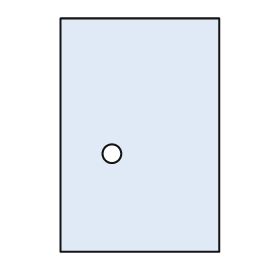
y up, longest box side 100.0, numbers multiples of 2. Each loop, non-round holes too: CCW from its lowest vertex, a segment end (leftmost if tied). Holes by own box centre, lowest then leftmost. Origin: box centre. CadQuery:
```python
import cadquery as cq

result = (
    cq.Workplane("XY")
    .moveTo(-34.0, -50.0)
    .lineTo(34.0, -50.0)
    .lineTo(34.0, 50.0)
    .lineTo(-34.0, 50.0)
    .close()
    .moveTo(-12.0, -8.0)
    .circle(4.0)
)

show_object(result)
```